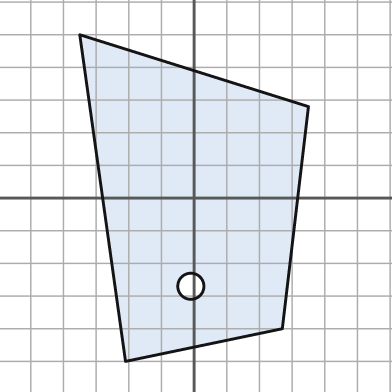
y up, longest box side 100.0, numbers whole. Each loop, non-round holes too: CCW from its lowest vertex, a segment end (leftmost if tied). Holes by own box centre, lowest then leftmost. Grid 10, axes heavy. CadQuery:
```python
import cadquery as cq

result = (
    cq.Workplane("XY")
    .moveTo(-21.0, -50.0)
    .lineTo(27.0, -40.0)
    .lineTo(35.0, 28.0)
    .lineTo(-35.0, 50.0)
    .close()
    .moveTo(-1.0, -27.0)
    .circle(4.0)
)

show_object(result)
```